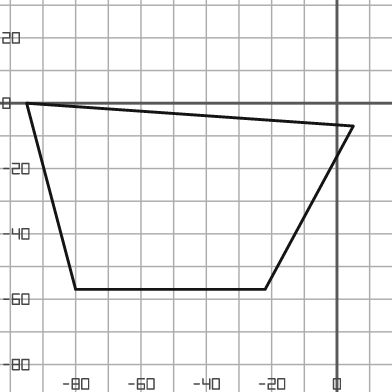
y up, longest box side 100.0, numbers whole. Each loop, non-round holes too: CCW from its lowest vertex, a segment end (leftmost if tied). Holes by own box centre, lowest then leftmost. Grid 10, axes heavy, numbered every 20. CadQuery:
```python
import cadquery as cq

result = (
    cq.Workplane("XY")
    .moveTo(-80.0, -57.0)
    .lineTo(-22.0, -57.0)
    .lineTo(5.0, -7.0)
    .lineTo(-95.0, 0.0)
    .close()
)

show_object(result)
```